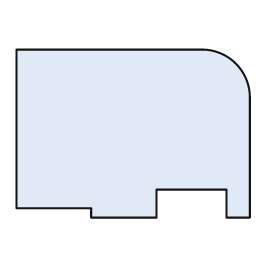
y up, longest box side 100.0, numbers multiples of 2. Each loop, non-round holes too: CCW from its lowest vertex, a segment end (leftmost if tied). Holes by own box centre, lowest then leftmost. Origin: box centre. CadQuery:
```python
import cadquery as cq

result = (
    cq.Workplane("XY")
    .moveTo(-18.0, -36.0)
    .lineTo(10.0, -36.0)
    .lineTo(10.0, -24.0)
    .lineTo(40.0, -24.0)
    .lineTo(40.0, -36.0)
    .lineTo(50.0, -36.0)
    .lineTo(50.0, 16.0)
    .threePointArc((44.0, 30.0), (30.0, 36.0))
    .lineTo(-50.0, 36.0)
    .lineTo(-50.0, -32.0)
    .lineTo(-18.0, -32.0)
    .close()
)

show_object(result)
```